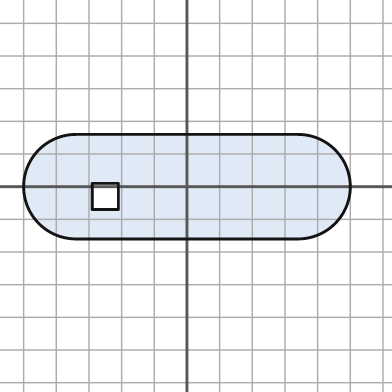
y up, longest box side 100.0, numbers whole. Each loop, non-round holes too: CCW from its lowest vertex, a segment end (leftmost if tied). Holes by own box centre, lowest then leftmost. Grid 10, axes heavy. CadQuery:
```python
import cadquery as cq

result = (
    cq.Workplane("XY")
    .moveTo(-34.0, -16.0)
    .lineTo(34.0, -16.0)
    .threePointArc((50.0, 0.0), (34.0, 16.0))
    .lineTo(-34.0, 16.0)
    .threePointArc((-50.0, 0.0), (-34.0, -16.0))
    .close()
    .moveTo(-29.0, -7.0)
    .lineTo(-21.0, -7.0)
    .lineTo(-21.0, 1.0)
    .lineTo(-29.0, 1.0)
    .close()
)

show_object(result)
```